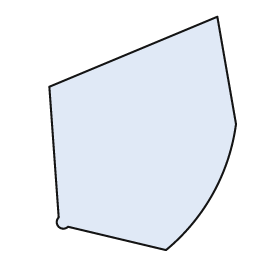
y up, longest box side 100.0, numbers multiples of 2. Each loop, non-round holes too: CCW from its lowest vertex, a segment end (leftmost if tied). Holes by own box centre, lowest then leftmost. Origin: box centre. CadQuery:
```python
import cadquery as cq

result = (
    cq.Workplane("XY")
    .moveTo(10.0, -50.0)
    .threePointArc((30.0, -26.0), (40.0, 4.0))
    .lineTo(32.0, 50.0)
    .lineTo(-40.0, 20.0)
    .lineTo(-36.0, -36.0)
    .threePointArc((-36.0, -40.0), (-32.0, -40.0))
    .close()
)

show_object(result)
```